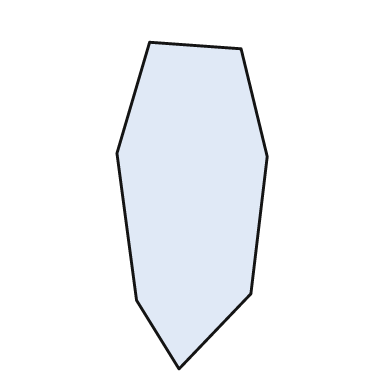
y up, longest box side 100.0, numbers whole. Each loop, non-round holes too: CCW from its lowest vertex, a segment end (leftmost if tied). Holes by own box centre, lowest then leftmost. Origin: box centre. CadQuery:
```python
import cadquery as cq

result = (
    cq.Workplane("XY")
    .moveTo(-4.0, -50.0)
    .lineTo(18.0, -27.0)
    .lineTo(23.0, 15.0)
    .lineTo(15.0, 48.0)
    .lineTo(-13.0, 50.0)
    .lineTo(-23.0, 16.0)
    .lineTo(-17.0, -29.0)
    .close()
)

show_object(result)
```